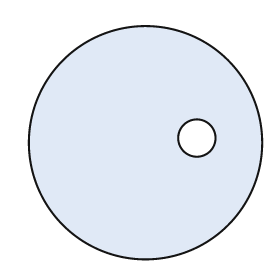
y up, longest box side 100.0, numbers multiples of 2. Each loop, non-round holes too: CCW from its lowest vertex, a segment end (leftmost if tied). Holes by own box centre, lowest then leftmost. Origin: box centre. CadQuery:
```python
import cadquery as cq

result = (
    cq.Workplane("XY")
    .moveTo(0.0, 0.0)
    .circle(50.0)
    .moveTo(22.0, 2.0)
    .circle(8.0)
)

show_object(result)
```